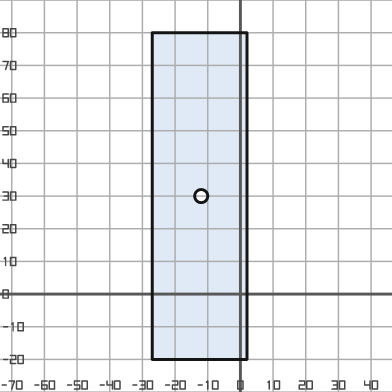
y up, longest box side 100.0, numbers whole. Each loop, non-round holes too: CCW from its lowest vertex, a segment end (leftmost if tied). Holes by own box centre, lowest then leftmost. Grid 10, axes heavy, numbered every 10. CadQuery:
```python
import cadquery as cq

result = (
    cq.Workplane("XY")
    .moveTo(-27.0, -20.0)
    .lineTo(2.0, -20.0)
    .lineTo(2.0, 80.0)
    .lineTo(-27.0, 80.0)
    .close()
    .moveTo(-12.0, 30.0)
    .circle(2.0)
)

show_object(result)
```